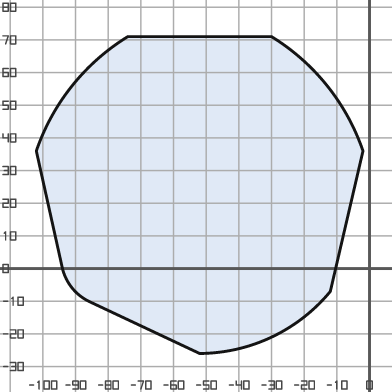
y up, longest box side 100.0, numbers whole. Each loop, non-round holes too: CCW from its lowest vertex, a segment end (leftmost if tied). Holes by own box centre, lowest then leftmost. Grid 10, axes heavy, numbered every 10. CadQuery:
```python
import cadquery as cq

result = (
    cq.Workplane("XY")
    .moveTo(-52.0, -26.0)
    .threePointArc((-30.0, -21.0), (-12.0, -7.0))
    .lineTo(-2.0, 36.0)
    .threePointArc((-13.0, 56.0), (-30.0, 71.0))
    .lineTo(-74.0, 71.0)
    .threePointArc((-91.0, 56.0), (-102.0, 36.0))
    .lineTo(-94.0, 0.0)
    .threePointArc((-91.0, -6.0), (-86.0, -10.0))
    .close()
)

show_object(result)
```